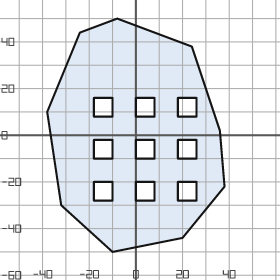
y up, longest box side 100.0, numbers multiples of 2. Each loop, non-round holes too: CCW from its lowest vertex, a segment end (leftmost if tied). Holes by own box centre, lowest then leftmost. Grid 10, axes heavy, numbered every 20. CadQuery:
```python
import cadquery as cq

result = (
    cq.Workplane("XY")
    .moveTo(-10.0, -50.0)
    .lineTo(20.0, -44.0)
    .lineTo(38.0, -22.0)
    .lineTo(36.0, 2.0)
    .lineTo(24.0, 38.0)
    .lineTo(-8.0, 50.0)
    .lineTo(-24.0, 44.0)
    .lineTo(-38.0, 10.0)
    .lineTo(-32.0, -30.0)
    .close()
    .moveTo(-18.0, -28.0)
    .lineTo(-10.0, -28.0)
    .lineTo(-10.0, -20.0)
    .lineTo(-18.0, -20.0)
    .close()
    .moveTo(0.0, -28.0)
    .lineTo(8.0, -28.0)
    .lineTo(8.0, -20.0)
    .lineTo(0.0, -20.0)
    .close()
    .moveTo(18.0, -28.0)
    .lineTo(26.0, -28.0)
    .lineTo(26.0, -20.0)
    .lineTo(18.0, -20.0)
    .close()
    .moveTo(-18.0, -10.0)
    .lineTo(-10.0, -10.0)
    .lineTo(-10.0, -2.0)
    .lineTo(-18.0, -2.0)
    .close()
    .moveTo(0.0, -10.0)
    .lineTo(8.0, -10.0)
    .lineTo(8.0, -2.0)
    .lineTo(0.0, -2.0)
    .close()
    .moveTo(18.0, -10.0)
    .lineTo(26.0, -10.0)
    .lineTo(26.0, -2.0)
    .lineTo(18.0, -2.0)
    .close()
    .moveTo(-18.0, 8.0)
    .lineTo(-10.0, 8.0)
    .lineTo(-10.0, 16.0)
    .lineTo(-18.0, 16.0)
    .close()
    .moveTo(0.0, 8.0)
    .lineTo(8.0, 8.0)
    .lineTo(8.0, 16.0)
    .lineTo(0.0, 16.0)
    .close()
    .moveTo(18.0, 8.0)
    .lineTo(26.0, 8.0)
    .lineTo(26.0, 16.0)
    .lineTo(18.0, 16.0)
    .close()
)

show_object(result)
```